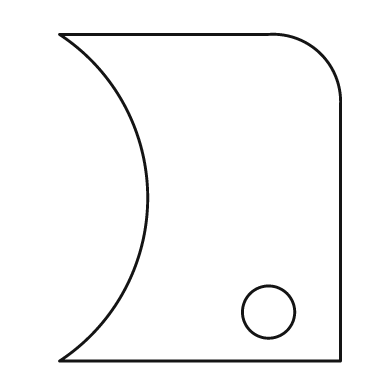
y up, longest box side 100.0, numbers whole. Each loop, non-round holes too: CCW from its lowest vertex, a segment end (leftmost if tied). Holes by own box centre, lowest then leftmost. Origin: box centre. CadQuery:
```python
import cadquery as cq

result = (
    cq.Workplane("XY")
    .moveTo(-43.0, -50.0)
    .lineTo(43.0, -50.0)
    .lineTo(43.0, 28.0)
    .threePointArc((37.0, 44.0), (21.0, 50.0))
    .lineTo(-43.0, 50.0)
    .threePointArc((-16.0, 0.0), (-43.0, -50.0))
    .close()
    .moveTo(21.0, -35.0)
    .circle(8.0)
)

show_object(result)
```